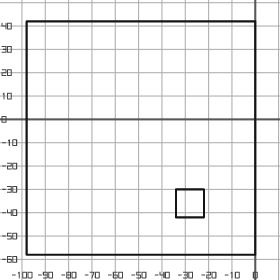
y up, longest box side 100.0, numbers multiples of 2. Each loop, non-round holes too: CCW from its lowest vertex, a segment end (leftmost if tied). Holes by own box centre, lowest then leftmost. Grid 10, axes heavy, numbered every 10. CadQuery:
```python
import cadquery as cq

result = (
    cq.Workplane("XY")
    .moveTo(-98.0, -58.0)
    .lineTo(0.0, -58.0)
    .lineTo(0.0, 42.0)
    .lineTo(-98.0, 42.0)
    .close()
    .moveTo(-34.0, -42.0)
    .lineTo(-22.0, -42.0)
    .lineTo(-22.0, -30.0)
    .lineTo(-34.0, -30.0)
    .close()
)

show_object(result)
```